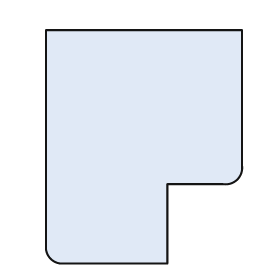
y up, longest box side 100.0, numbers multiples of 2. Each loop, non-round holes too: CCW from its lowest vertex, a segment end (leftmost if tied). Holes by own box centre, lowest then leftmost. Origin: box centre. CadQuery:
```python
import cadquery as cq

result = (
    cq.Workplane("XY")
    .moveTo(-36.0, -50.0)
    .lineTo(10.0, -50.0)
    .lineTo(10.0, -16.0)
    .lineTo(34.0, -16.0)
    .threePointArc((40.0, -14.0), (42.0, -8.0))
    .lineTo(42.0, 50.0)
    .lineTo(-42.0, 50.0)
    .lineTo(-42.0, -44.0)
    .threePointArc((-40.0, -48.0), (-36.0, -50.0))
    .close()
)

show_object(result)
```